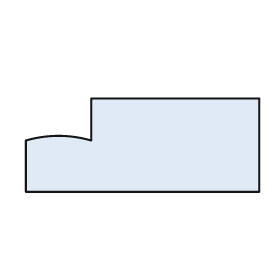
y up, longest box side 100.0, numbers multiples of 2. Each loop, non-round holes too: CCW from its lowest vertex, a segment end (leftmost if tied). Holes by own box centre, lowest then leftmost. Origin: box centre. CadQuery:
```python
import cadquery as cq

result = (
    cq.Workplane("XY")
    .moveTo(-50.0, -20.0)
    .lineTo(50.0, -20.0)
    .lineTo(50.0, 20.0)
    .lineTo(-22.0, 20.0)
    .lineTo(-22.0, 2.0)
    .threePointArc((-36.0, 4.0), (-50.0, 2.0))
    .close()
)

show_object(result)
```